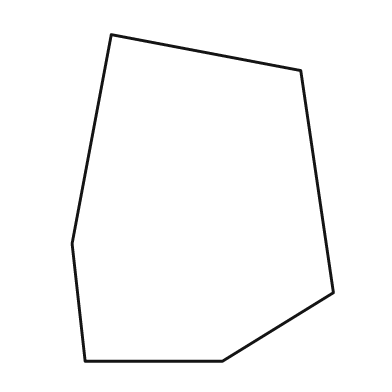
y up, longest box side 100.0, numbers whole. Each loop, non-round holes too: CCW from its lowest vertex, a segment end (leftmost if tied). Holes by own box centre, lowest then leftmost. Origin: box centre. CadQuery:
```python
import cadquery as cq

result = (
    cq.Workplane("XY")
    .moveTo(-36.0, -50.0)
    .lineTo(6.0, -50.0)
    .lineTo(40.0, -29.0)
    .lineTo(30.0, 39.0)
    .lineTo(-28.0, 50.0)
    .lineTo(-40.0, -14.0)
    .close()
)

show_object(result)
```